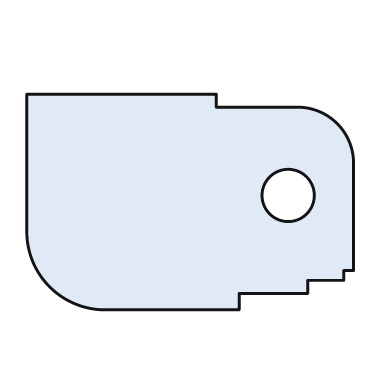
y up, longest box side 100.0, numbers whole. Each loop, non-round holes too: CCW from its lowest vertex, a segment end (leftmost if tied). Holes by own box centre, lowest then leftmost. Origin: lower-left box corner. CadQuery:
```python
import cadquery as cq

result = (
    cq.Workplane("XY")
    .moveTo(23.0, 0.0)
    .lineTo(65.0, 0.0)
    .lineTo(65.0, 5.0)
    .lineTo(86.0, 5.0)
    .lineTo(86.0, 9.0)
    .lineTo(97.0, 9.0)
    .lineTo(97.0, 12.0)
    .lineTo(100.0, 12.0)
    .lineTo(100.0, 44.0)
    .threePointArc((95.0, 57.0), (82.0, 62.0))
    .lineTo(58.0, 62.0)
    .lineTo(58.0, 66.0)
    .lineTo(0.0, 66.0)
    .lineTo(0.0, 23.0)
    .threePointArc((7.0, 7.0), (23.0, 0.0))
    .close()
    .moveTo(80.0, 35.0)
    .circle(8.0)
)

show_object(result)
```